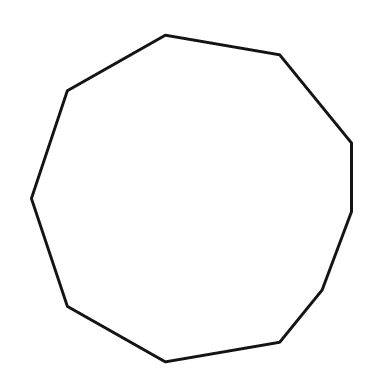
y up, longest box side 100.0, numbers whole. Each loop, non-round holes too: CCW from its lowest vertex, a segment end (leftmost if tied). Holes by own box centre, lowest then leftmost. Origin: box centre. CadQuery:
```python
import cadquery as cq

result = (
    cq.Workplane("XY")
    .moveTo(-8.0, -50.0)
    .lineTo(27.0, -44.0)
    .lineTo(40.0, -28.0)
    .lineTo(49.0, -4.0)
    .lineTo(49.0, 17.0)
    .lineTo(27.0, 44.0)
    .lineTo(-8.0, 50.0)
    .lineTo(-38.0, 33.0)
    .lineTo(-49.0, 0.0)
    .lineTo(-38.0, -33.0)
    .close()
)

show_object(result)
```